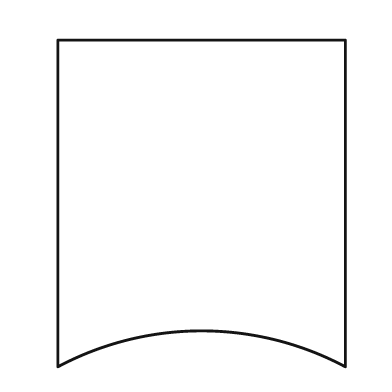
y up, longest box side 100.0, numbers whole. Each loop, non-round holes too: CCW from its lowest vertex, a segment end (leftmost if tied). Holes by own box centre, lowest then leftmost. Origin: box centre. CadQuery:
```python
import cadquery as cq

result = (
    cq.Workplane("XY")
    .moveTo(-44.0, -50.0)
    .threePointArc((0.0, -39.0), (44.0, -50.0))
    .lineTo(44.0, 50.0)
    .lineTo(-44.0, 50.0)
    .close()
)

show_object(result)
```